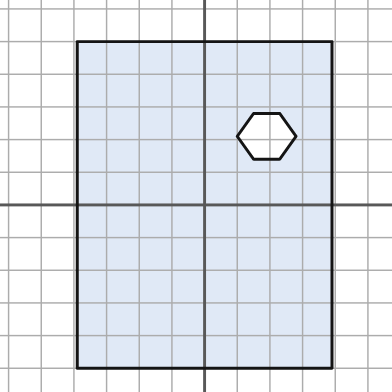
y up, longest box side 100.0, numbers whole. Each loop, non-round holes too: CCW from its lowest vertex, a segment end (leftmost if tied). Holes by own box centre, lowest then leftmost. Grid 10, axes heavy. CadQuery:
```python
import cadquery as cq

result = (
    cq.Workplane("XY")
    .moveTo(-39.0, -50.0)
    .lineTo(39.0, -50.0)
    .lineTo(39.0, 50.0)
    .lineTo(-39.0, 50.0)
    .close()
    .moveTo(15.0, 14.0)
    .lineTo(23.0, 14.0)
    .lineTo(28.0, 21.0)
    .lineTo(23.0, 28.0)
    .lineTo(15.0, 28.0)
    .lineTo(10.0, 21.0)
    .close()
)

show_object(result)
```